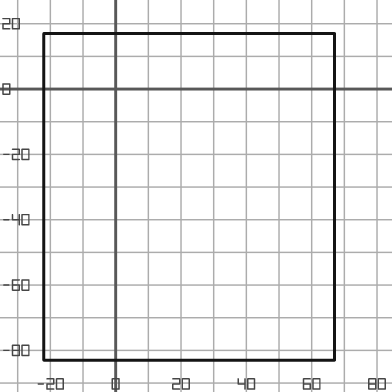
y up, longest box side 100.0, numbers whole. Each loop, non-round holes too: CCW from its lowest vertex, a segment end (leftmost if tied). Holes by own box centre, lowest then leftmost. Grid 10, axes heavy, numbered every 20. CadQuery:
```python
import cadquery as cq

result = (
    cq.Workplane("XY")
    .moveTo(-22.0, -83.0)
    .lineTo(67.0, -83.0)
    .lineTo(67.0, 17.0)
    .lineTo(-22.0, 17.0)
    .close()
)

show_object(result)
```